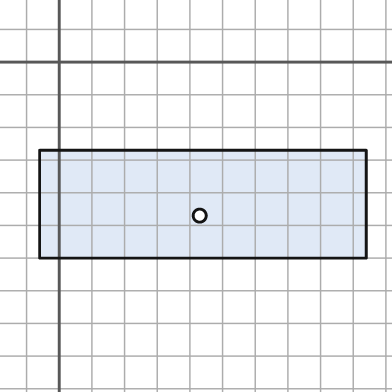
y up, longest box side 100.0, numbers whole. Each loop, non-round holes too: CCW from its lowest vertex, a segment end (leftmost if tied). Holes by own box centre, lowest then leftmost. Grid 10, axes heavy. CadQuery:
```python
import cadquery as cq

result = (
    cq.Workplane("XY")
    .moveTo(-6.0, -60.0)
    .lineTo(94.0, -60.0)
    .lineTo(94.0, -27.0)
    .lineTo(-6.0, -27.0)
    .close()
    .moveTo(43.0, -47.0)
    .circle(2.0)
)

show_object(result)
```